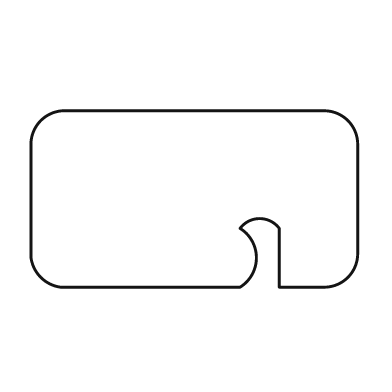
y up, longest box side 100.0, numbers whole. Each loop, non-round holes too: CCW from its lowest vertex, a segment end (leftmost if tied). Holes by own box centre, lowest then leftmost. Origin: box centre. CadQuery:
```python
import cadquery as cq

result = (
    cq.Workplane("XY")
    .moveTo(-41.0, -27.0)
    .lineTo(14.0, -27.0)
    .threePointArc((19.0, -18.0), (14.0, -9.0))
    .threePointArc((20.0, -6.0), (26.0, -9.0))
    .lineTo(26.0, -27.0)
    .lineTo(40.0, -27.0)
    .threePointArc((47.0, -24.0), (50.0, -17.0))
    .lineTo(50.0, 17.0)
    .threePointArc((47.0, 24.0), (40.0, 27.0))
    .lineTo(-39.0, 27.0)
    .threePointArc((-47.0, 24.0), (-50.0, 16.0))
    .lineTo(-50.0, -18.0)
    .threePointArc((-47.0, -24.0), (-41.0, -27.0))
    .close()
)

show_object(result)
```